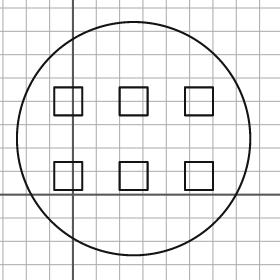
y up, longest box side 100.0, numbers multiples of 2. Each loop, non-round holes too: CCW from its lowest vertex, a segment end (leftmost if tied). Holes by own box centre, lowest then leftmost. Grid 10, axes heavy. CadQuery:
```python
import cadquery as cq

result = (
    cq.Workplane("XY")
    .moveTo(26.0, 24.0)
    .circle(50.0)
    .moveTo(-8.0, 2.0)
    .lineTo(4.0, 2.0)
    .lineTo(4.0, 14.0)
    .lineTo(-8.0, 14.0)
    .close()
    .moveTo(20.0, 2.0)
    .lineTo(32.0, 2.0)
    .lineTo(32.0, 14.0)
    .lineTo(20.0, 14.0)
    .close()
    .moveTo(48.0, 2.0)
    .lineTo(60.0, 2.0)
    .lineTo(60.0, 14.0)
    .lineTo(48.0, 14.0)
    .close()
    .moveTo(-8.0, 34.0)
    .lineTo(4.0, 34.0)
    .lineTo(4.0, 46.0)
    .lineTo(-8.0, 46.0)
    .close()
    .moveTo(20.0, 34.0)
    .lineTo(32.0, 34.0)
    .lineTo(32.0, 46.0)
    .lineTo(20.0, 46.0)
    .close()
    .moveTo(48.0, 34.0)
    .lineTo(60.0, 34.0)
    .lineTo(60.0, 46.0)
    .lineTo(48.0, 46.0)
    .close()
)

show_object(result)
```